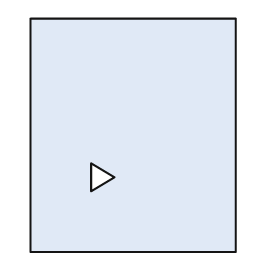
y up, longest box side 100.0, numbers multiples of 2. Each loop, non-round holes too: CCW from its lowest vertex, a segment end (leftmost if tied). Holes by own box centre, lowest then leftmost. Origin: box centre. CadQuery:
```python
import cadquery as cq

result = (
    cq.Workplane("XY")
    .moveTo(-44.0, -50.0)
    .lineTo(44.0, -50.0)
    .lineTo(44.0, 50.0)
    .lineTo(-44.0, 50.0)
    .close()
    .moveTo(-18.0, -24.0)
    .lineTo(-8.0, -18.0)
    .lineTo(-18.0, -12.0)
    .close()
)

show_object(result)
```